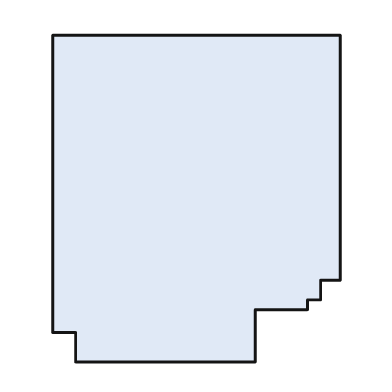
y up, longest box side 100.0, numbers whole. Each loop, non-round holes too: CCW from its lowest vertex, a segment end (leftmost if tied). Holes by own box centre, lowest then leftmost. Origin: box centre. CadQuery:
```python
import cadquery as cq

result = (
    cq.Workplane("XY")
    .moveTo(-37.0, -50.0)
    .lineTo(18.0, -50.0)
    .lineTo(18.0, -34.0)
    .lineTo(34.0, -34.0)
    .lineTo(34.0, -31.0)
    .lineTo(38.0, -31.0)
    .lineTo(38.0, -25.0)
    .lineTo(44.0, -25.0)
    .lineTo(44.0, 50.0)
    .lineTo(-44.0, 50.0)
    .lineTo(-44.0, -41.0)
    .lineTo(-37.0, -41.0)
    .close()
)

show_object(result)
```